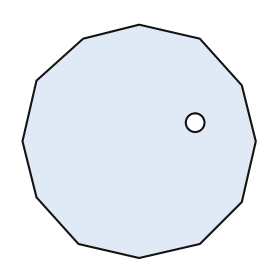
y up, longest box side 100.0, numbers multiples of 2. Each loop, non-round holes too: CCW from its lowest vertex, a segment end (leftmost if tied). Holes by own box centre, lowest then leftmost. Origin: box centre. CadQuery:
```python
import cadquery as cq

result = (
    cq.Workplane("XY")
    .moveTo(0.0, -50.0)
    .lineTo(26.0, -44.0)
    .lineTo(44.0, -26.0)
    .lineTo(50.0, 0.0)
    .lineTo(44.0, 24.0)
    .lineTo(26.0, 44.0)
    .lineTo(0.0, 50.0)
    .lineTo(-24.0, 44.0)
    .lineTo(-44.0, 26.0)
    .lineTo(-50.0, 0.0)
    .lineTo(-44.0, -24.0)
    .lineTo(-26.0, -44.0)
    .close()
    .moveTo(24.0, 8.0)
    .circle(4.0)
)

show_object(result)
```